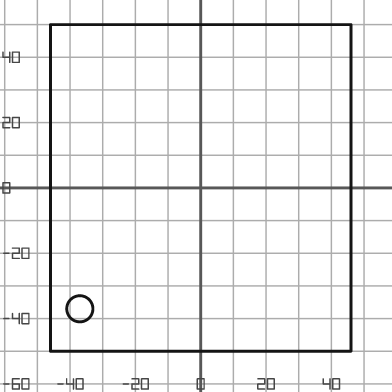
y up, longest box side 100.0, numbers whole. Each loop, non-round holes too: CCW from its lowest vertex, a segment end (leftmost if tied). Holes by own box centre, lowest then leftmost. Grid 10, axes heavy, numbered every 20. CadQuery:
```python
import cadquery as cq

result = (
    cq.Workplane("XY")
    .moveTo(-46.0, -50.0)
    .lineTo(46.0, -50.0)
    .lineTo(46.0, 50.0)
    .lineTo(-46.0, 50.0)
    .close()
    .moveTo(-37.0, -37.0)
    .circle(4.0)
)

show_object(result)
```